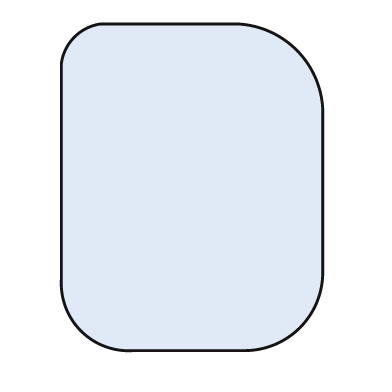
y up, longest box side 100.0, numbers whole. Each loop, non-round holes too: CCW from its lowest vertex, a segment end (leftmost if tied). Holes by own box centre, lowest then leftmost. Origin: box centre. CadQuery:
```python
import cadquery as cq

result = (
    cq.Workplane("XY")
    .moveTo(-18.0, -50.0)
    .lineTo(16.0, -50.0)
    .threePointArc((33.0, -43.0), (40.0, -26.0))
    .lineTo(40.0, 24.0)
    .threePointArc((32.0, 42.0), (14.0, 50.0))
    .lineTo(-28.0, 50.0)
    .threePointArc((-36.0, 46.0), (-40.0, 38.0))
    .lineTo(-40.0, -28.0)
    .threePointArc((-34.0, -44.0), (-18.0, -50.0))
    .close()
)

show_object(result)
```